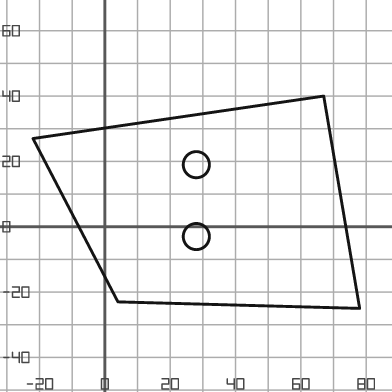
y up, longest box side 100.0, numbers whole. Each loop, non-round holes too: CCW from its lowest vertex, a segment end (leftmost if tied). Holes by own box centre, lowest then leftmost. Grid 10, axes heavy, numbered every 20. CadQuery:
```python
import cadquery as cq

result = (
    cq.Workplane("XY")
    .moveTo(78.0, -25.0)
    .lineTo(67.0, 40.0)
    .lineTo(-22.0, 27.0)
    .lineTo(4.0, -23.0)
    .close()
    .moveTo(28.0, -3.0)
    .circle(4.0)
    .moveTo(28.0, 19.0)
    .circle(4.0)
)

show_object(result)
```